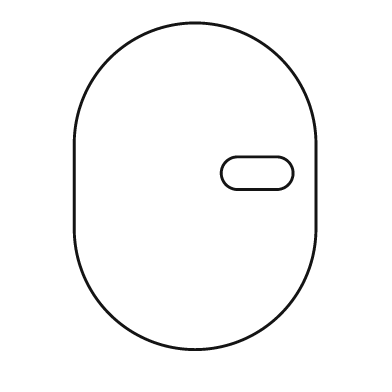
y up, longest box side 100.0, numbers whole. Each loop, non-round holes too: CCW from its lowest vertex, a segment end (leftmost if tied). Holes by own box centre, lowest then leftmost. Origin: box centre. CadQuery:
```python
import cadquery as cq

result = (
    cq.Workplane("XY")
    .moveTo(-37.0, -13.0)
    .threePointArc((0.0, -50.0), (37.0, -13.0))
    .lineTo(37.0, 13.0)
    .threePointArc((0.0, 50.0), (-37.0, 13.0))
    .close()
    .moveTo(13.0, -1.0)
    .lineTo(25.0, -1.0)
    .threePointArc((30.0, 4.0), (25.0, 9.0))
    .lineTo(13.0, 9.0)
    .threePointArc((8.0, 4.0), (13.0, -1.0))
    .close()
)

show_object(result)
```